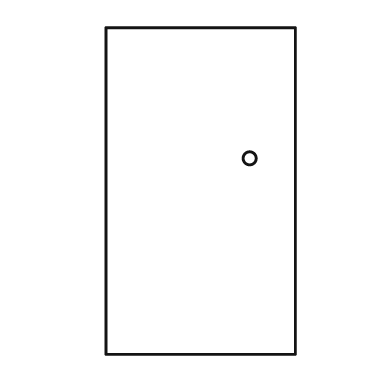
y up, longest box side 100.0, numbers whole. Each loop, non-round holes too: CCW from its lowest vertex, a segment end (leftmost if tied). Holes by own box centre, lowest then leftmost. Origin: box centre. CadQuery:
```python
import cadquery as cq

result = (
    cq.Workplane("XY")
    .moveTo(-29.0, -50.0)
    .lineTo(29.0, -50.0)
    .lineTo(29.0, 50.0)
    .lineTo(-29.0, 50.0)
    .close()
    .moveTo(15.0, 10.0)
    .circle(2.0)
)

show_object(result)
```